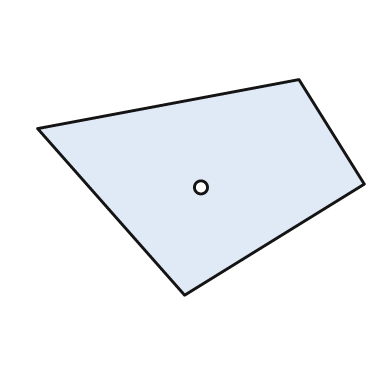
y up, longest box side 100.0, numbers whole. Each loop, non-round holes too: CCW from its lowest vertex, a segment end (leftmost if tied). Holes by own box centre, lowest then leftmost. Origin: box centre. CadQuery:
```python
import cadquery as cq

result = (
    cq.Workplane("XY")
    .moveTo(-5.0, -33.0)
    .lineTo(50.0, 1.0)
    .lineTo(30.0, 33.0)
    .lineTo(-50.0, 18.0)
    .close()
    .moveTo(0.0, 0.0)
    .circle(2.0)
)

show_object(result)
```